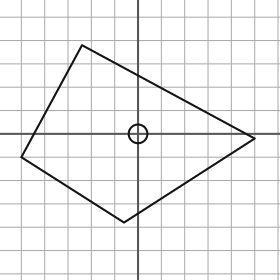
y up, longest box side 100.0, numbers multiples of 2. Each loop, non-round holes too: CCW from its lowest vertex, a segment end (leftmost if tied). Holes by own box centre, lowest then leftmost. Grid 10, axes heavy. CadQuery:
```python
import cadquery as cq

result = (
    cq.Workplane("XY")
    .moveTo(-6.0, -38.0)
    .lineTo(50.0, -2.0)
    .lineTo(-24.0, 38.0)
    .lineTo(-50.0, -10.0)
    .close()
    .moveTo(0.0, 0.0)
    .circle(4.0)
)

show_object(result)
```